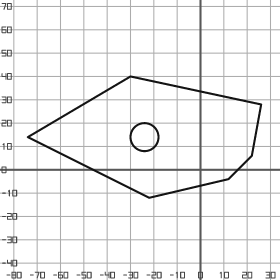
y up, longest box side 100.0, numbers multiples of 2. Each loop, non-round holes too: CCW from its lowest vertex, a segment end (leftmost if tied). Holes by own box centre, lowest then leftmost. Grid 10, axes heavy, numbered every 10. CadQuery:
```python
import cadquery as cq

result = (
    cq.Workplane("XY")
    .moveTo(-22.0, -12.0)
    .lineTo(12.0, -4.0)
    .lineTo(22.0, 6.0)
    .lineTo(26.0, 28.0)
    .lineTo(-30.0, 40.0)
    .lineTo(-74.0, 14.0)
    .close()
    .moveTo(-24.0, 14.0)
    .circle(6.0)
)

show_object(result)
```